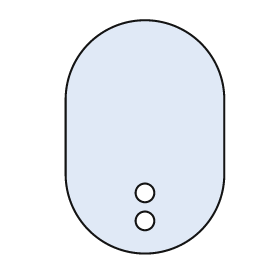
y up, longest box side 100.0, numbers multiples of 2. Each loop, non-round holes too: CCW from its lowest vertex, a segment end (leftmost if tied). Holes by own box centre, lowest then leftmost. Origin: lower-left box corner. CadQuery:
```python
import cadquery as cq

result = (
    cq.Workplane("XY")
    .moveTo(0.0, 34.0)
    .threePointArc((34.0, 0.0), (68.0, 34.0))
    .lineTo(68.0, 66.0)
    .threePointArc((34.0, 100.0), (0.0, 66.0))
    .close()
    .moveTo(34.0, 14.0)
    .circle(4.0)
    .moveTo(34.0, 26.0)
    .circle(4.0)
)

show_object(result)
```